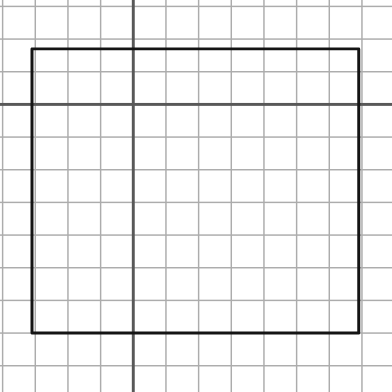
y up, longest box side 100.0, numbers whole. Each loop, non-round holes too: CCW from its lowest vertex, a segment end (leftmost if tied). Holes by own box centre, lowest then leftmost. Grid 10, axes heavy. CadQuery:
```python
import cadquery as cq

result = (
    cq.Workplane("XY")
    .moveTo(-31.0, -70.0)
    .lineTo(69.0, -70.0)
    .lineTo(69.0, 17.0)
    .lineTo(-31.0, 17.0)
    .close()
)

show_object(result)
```